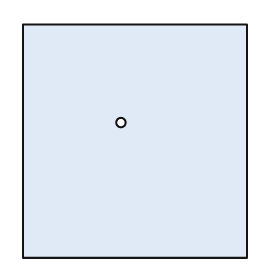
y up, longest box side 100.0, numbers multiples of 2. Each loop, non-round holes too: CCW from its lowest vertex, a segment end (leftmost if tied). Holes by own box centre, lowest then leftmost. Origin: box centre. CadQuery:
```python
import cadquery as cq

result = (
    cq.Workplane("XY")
    .moveTo(-48.0, -50.0)
    .lineTo(48.0, -50.0)
    .lineTo(48.0, 50.0)
    .lineTo(-48.0, 50.0)
    .close()
    .moveTo(-6.0, 8.0)
    .circle(2.0)
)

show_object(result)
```